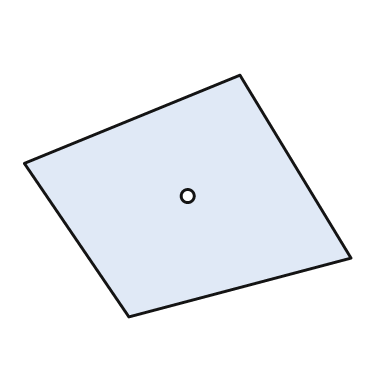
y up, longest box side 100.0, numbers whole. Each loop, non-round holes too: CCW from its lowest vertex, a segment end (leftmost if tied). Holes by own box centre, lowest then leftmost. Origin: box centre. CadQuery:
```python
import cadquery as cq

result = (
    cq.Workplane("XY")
    .moveTo(-18.0, -37.0)
    .lineTo(50.0, -19.0)
    .lineTo(16.0, 37.0)
    .lineTo(-50.0, 10.0)
    .close()
    .moveTo(0.0, 0.0)
    .circle(2.0)
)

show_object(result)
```